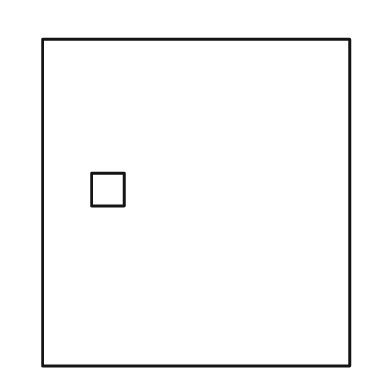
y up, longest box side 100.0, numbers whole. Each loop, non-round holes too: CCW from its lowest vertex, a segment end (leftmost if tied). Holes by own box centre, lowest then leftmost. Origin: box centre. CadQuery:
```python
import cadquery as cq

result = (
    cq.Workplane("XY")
    .moveTo(-47.0, -50.0)
    .lineTo(47.0, -50.0)
    .lineTo(47.0, 50.0)
    .lineTo(-47.0, 50.0)
    .close()
    .moveTo(-32.0, -1.0)
    .lineTo(-22.0, -1.0)
    .lineTo(-22.0, 9.0)
    .lineTo(-32.0, 9.0)
    .close()
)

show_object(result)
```